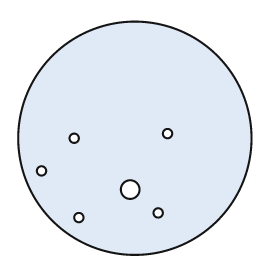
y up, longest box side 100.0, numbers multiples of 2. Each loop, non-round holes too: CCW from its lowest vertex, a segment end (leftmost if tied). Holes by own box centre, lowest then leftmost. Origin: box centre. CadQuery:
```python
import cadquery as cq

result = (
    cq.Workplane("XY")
    .moveTo(0.0, 0.0)
    .circle(50.0)
    .moveTo(-24.0, -34.0)
    .circle(2.0)
    .moveTo(10.0, -32.0)
    .circle(2.0)
    .moveTo(-2.0, -22.0)
    .circle(4.0)
    .moveTo(-40.0, -14.0)
    .circle(2.0)
    .moveTo(-26.0, 0.0)
    .circle(2.0)
    .moveTo(14.0, 2.0)
    .circle(2.0)
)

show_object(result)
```